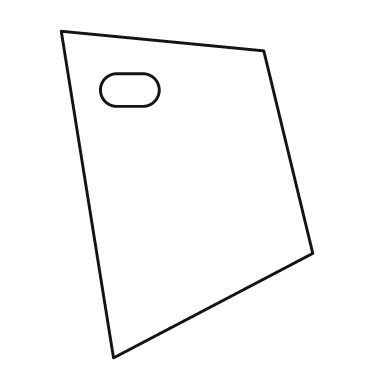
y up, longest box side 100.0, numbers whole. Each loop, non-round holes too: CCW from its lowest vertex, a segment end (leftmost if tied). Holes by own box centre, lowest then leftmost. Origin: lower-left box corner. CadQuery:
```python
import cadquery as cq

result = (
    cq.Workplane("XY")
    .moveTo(16.0, 0.0)
    .lineTo(77.0, 32.0)
    .lineTo(62.0, 94.0)
    .lineTo(0.0, 100.0)
    .close()
    .moveTo(17.0, 77.0)
    .lineTo(25.0, 77.0)
    .threePointArc((30.0, 82.0), (25.0, 87.0))
    .lineTo(17.0, 87.0)
    .threePointArc((12.0, 82.0), (17.0, 77.0))
    .close()
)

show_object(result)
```